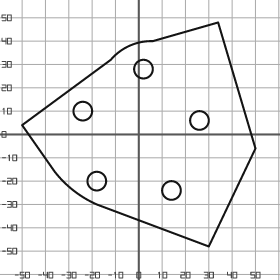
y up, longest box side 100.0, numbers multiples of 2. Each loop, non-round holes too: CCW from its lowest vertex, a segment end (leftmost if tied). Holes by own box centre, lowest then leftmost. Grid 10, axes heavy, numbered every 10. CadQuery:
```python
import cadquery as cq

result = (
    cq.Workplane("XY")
    .moveTo(30.0, -48.0)
    .lineTo(50.0, -6.0)
    .lineTo(34.0, 48.0)
    .lineTo(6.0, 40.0)
    .threePointArc((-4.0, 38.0), (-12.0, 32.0))
    .lineTo(-50.0, 4.0)
    .lineTo(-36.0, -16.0)
    .threePointArc((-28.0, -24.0), (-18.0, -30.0))
    .close()
    .moveTo(14.0, -24.0)
    .circle(4.0)
    .moveTo(-18.0, -20.0)
    .circle(4.0)
    .moveTo(26.0, 6.0)
    .circle(4.0)
    .moveTo(-24.0, 10.0)
    .circle(4.0)
    .moveTo(2.0, 28.0)
    .circle(4.0)
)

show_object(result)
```